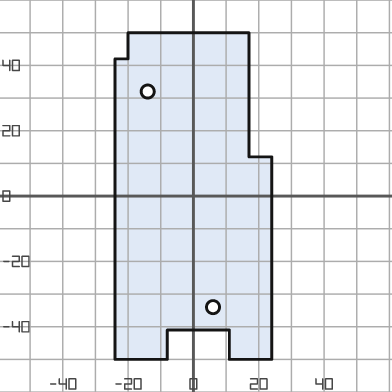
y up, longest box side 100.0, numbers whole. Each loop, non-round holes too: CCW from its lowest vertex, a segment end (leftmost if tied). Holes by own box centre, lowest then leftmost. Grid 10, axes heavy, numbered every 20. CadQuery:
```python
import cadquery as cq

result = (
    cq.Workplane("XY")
    .moveTo(-24.0, -50.0)
    .lineTo(-8.0, -50.0)
    .lineTo(-8.0, -41.0)
    .lineTo(11.0, -41.0)
    .lineTo(11.0, -50.0)
    .lineTo(24.0, -50.0)
    .lineTo(24.0, 12.0)
    .lineTo(17.0, 12.0)
    .lineTo(17.0, 50.0)
    .lineTo(-20.0, 50.0)
    .lineTo(-20.0, 42.0)
    .lineTo(-24.0, 42.0)
    .close()
    .moveTo(6.0, -34.0)
    .circle(2.0)
    .moveTo(-14.0, 32.0)
    .circle(2.0)
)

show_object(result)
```